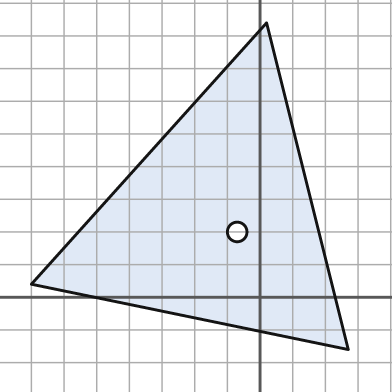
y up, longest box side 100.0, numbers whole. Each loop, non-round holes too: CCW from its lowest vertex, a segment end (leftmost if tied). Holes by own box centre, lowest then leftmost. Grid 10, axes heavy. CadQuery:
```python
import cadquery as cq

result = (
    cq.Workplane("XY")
    .moveTo(27.0, -16.0)
    .lineTo(2.0, 84.0)
    .lineTo(-70.0, 4.0)
    .close()
    .moveTo(-7.0, 20.0)
    .circle(3.0)
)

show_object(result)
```